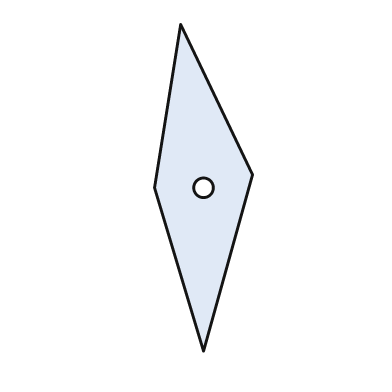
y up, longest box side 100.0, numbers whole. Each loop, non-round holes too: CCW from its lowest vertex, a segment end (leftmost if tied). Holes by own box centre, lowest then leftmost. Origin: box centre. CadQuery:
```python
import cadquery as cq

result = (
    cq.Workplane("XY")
    .moveTo(0.0, -50.0)
    .lineTo(15.0, 4.0)
    .lineTo(-7.0, 50.0)
    .lineTo(-15.0, 0.0)
    .close()
    .moveTo(0.0, 0.0)
    .circle(3.0)
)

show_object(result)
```